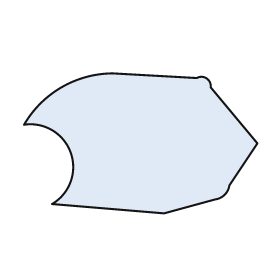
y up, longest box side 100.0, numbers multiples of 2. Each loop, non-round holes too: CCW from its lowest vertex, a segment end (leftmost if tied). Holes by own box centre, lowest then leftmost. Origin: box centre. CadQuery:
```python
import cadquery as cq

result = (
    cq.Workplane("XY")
    .moveTo(10.0, -30.0)
    .lineTo(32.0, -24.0)
    .threePointArc((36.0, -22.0), (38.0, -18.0))
    .lineTo(50.0, 0.0)
    .lineTo(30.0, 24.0)
    .threePointArc((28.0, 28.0), (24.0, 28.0))
    .lineTo(-12.0, 30.0)
    .threePointArc((-34.0, 24.0), (-50.0, 8.0))
    .threePointArc((-30.0, -4.0), (-38.0, -26.0))
    .close()
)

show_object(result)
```